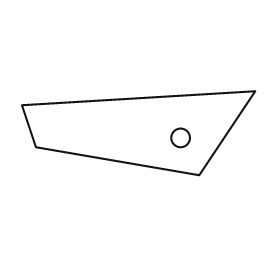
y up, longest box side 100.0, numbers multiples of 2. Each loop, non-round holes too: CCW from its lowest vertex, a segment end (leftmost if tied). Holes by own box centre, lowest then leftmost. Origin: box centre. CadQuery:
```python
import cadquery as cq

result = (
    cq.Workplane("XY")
    .moveTo(26.0, -18.0)
    .lineTo(50.0, 18.0)
    .lineTo(-50.0, 12.0)
    .lineTo(-44.0, -6.0)
    .close()
    .moveTo(18.0, -2.0)
    .circle(4.0)
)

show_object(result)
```